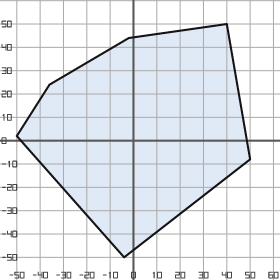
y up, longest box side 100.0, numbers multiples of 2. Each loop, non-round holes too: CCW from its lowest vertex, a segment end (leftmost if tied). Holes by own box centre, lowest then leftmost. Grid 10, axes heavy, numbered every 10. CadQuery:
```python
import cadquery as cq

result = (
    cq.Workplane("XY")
    .moveTo(-4.0, -50.0)
    .lineTo(50.0, -8.0)
    .lineTo(40.0, 50.0)
    .lineTo(-2.0, 44.0)
    .lineTo(-36.0, 24.0)
    .lineTo(-50.0, 2.0)
    .close()
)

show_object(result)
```